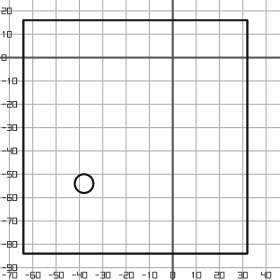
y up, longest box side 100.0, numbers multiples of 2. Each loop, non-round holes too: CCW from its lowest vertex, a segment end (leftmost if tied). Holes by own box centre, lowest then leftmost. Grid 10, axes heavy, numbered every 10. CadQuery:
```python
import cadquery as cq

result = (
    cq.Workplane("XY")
    .moveTo(-64.0, -84.0)
    .lineTo(32.0, -84.0)
    .lineTo(32.0, 16.0)
    .lineTo(-64.0, 16.0)
    .close()
    .moveTo(-38.0, -54.0)
    .circle(4.0)
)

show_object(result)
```